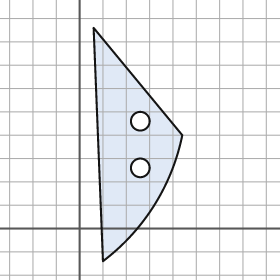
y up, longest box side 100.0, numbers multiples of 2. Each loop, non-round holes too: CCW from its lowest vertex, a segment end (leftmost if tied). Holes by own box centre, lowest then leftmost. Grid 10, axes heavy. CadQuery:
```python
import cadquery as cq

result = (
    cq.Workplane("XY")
    .moveTo(10.0, -14.0)
    .threePointArc((32.0, 10.0), (44.0, 40.0))
    .lineTo(6.0, 86.0)
    .close()
    .moveTo(26.0, 26.0)
    .circle(4.0)
    .moveTo(26.0, 46.0)
    .circle(4.0)
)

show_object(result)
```